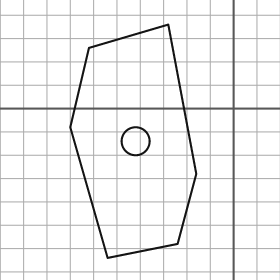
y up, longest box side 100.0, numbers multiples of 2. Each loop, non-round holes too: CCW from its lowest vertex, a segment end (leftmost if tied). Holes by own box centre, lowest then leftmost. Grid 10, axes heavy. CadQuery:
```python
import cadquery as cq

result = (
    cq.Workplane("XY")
    .moveTo(-54.0, -64.0)
    .lineTo(-24.0, -58.0)
    .lineTo(-16.0, -28.0)
    .lineTo(-28.0, 36.0)
    .lineTo(-62.0, 26.0)
    .lineTo(-70.0, -8.0)
    .close()
    .moveTo(-42.0, -14.0)
    .circle(6.0)
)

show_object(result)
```